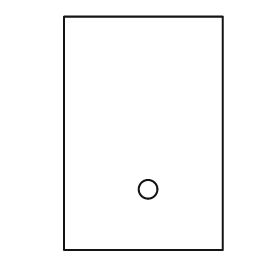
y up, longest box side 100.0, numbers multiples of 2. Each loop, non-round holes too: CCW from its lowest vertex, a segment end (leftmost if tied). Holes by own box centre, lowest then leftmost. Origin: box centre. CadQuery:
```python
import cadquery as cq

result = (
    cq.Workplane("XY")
    .moveTo(-34.0, -50.0)
    .lineTo(34.0, -50.0)
    .lineTo(34.0, 50.0)
    .lineTo(-34.0, 50.0)
    .close()
    .moveTo(2.0, -24.0)
    .circle(4.0)
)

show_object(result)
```